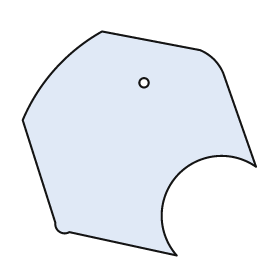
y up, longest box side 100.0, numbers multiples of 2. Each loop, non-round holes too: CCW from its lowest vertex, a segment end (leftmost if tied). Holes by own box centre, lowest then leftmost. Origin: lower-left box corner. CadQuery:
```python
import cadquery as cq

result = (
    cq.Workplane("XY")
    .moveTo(66.0, 0.0)
    .threePointArc((66.0, 34.0), (100.0, 38.0))
    .lineTo(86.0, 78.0)
    .threePointArc((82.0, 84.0), (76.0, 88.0))
    .lineTo(34.0, 96.0)
    .threePointArc((14.0, 80.0), (0.0, 58.0))
    .lineTo(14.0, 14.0)
    .threePointArc((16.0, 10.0), (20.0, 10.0))
    .close()
    .moveTo(52.0, 74.0)
    .circle(2.0)
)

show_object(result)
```